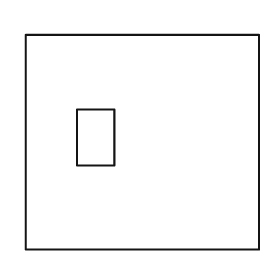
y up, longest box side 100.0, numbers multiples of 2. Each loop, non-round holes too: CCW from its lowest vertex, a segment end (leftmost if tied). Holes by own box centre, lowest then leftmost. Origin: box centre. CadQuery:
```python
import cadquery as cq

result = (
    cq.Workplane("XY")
    .moveTo(-50.0, -46.0)
    .lineTo(50.0, -46.0)
    .lineTo(50.0, 46.0)
    .lineTo(-50.0, 46.0)
    .close()
    .moveTo(-28.0, -10.0)
    .lineTo(-12.0, -10.0)
    .lineTo(-12.0, 14.0)
    .lineTo(-28.0, 14.0)
    .close()
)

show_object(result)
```